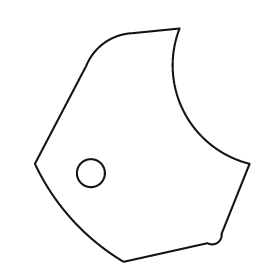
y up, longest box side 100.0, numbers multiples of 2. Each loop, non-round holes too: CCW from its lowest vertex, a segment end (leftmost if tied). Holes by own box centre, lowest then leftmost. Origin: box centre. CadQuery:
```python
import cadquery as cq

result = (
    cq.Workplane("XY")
    .moveTo(-8.0, -50.0)
    .lineTo(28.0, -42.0)
    .threePointArc((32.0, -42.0), (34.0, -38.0))
    .lineTo(46.0, -8.0)
    .threePointArc((18.0, 14.0), (16.0, 50.0))
    .lineTo(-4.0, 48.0)
    .threePointArc((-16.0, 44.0), (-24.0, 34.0))
    .lineTo(-46.0, -8.0)
    .threePointArc((-30.0, -32.0), (-8.0, -50.0))
    .close()
    .moveTo(-22.0, -12.0)
    .circle(6.0)
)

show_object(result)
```